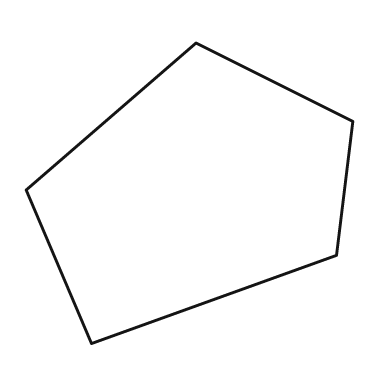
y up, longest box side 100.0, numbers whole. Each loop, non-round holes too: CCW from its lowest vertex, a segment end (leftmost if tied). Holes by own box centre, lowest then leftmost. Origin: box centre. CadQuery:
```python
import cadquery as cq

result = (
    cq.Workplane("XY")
    .moveTo(-30.0, -46.0)
    .lineTo(45.0, -19.0)
    .lineTo(50.0, 22.0)
    .lineTo(2.0, 46.0)
    .lineTo(-50.0, 1.0)
    .close()
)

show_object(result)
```